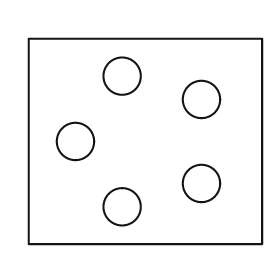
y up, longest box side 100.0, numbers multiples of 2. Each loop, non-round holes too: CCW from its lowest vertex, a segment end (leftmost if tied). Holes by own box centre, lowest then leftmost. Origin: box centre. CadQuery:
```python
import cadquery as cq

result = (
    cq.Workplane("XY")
    .moveTo(-50.0, -44.0)
    .lineTo(50.0, -44.0)
    .lineTo(50.0, 44.0)
    .lineTo(-50.0, 44.0)
    .close()
    .moveTo(-10.0, -28.0)
    .circle(8.0)
    .moveTo(24.0, -18.0)
    .circle(8.0)
    .moveTo(-30.0, 0.0)
    .circle(8.0)
    .moveTo(24.0, 18.0)
    .circle(8.0)
    .moveTo(-10.0, 28.0)
    .circle(8.0)
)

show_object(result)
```